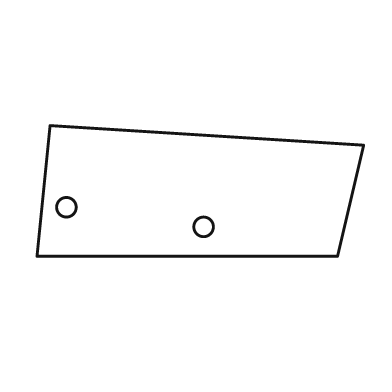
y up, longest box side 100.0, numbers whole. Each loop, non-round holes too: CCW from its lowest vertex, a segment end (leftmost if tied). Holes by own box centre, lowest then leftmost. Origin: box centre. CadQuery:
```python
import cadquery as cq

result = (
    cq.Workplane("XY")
    .moveTo(-50.0, -20.0)
    .lineTo(42.0, -20.0)
    .lineTo(50.0, 14.0)
    .lineTo(-46.0, 20.0)
    .close()
    .moveTo(1.0, -11.0)
    .circle(3.0)
    .moveTo(-41.0, -5.0)
    .circle(3.0)
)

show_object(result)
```